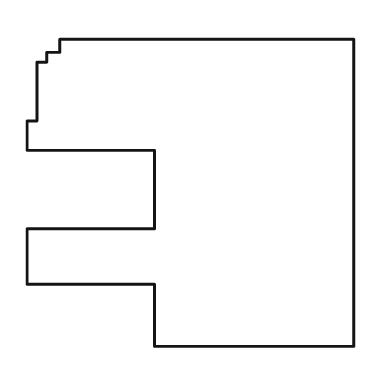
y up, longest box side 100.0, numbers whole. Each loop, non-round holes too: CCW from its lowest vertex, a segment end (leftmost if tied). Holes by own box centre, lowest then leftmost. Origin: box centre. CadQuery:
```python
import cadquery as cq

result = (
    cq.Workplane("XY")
    .moveTo(-11.0, -47.0)
    .lineTo(50.0, -47.0)
    .lineTo(50.0, 47.0)
    .lineTo(-40.0, 47.0)
    .lineTo(-40.0, 43.0)
    .lineTo(-44.0, 43.0)
    .lineTo(-44.0, 40.0)
    .lineTo(-47.0, 40.0)
    .lineTo(-47.0, 22.0)
    .lineTo(-50.0, 22.0)
    .lineTo(-50.0, 13.0)
    .lineTo(-11.0, 13.0)
    .lineTo(-11.0, -11.0)
    .lineTo(-50.0, -11.0)
    .lineTo(-50.0, -28.0)
    .lineTo(-11.0, -28.0)
    .close()
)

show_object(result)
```